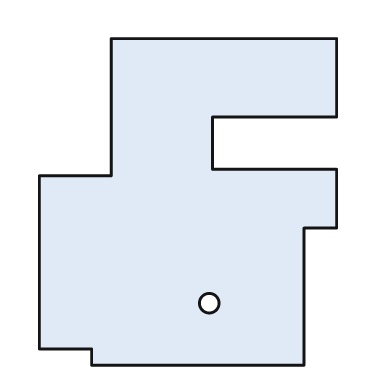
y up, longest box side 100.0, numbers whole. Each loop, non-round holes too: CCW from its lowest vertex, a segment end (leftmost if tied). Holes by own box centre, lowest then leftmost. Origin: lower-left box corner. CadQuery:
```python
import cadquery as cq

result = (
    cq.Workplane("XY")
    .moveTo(16.0, 0.0)
    .lineTo(81.0, 0.0)
    .lineTo(81.0, 42.0)
    .lineTo(91.0, 42.0)
    .lineTo(91.0, 60.0)
    .lineTo(53.0, 60.0)
    .lineTo(53.0, 76.0)
    .lineTo(91.0, 76.0)
    .lineTo(91.0, 100.0)
    .lineTo(22.0, 100.0)
    .lineTo(22.0, 58.0)
    .lineTo(0.0, 58.0)
    .lineTo(0.0, 5.0)
    .lineTo(16.0, 5.0)
    .close()
    .moveTo(52.0, 19.0)
    .circle(3.0)
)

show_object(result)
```